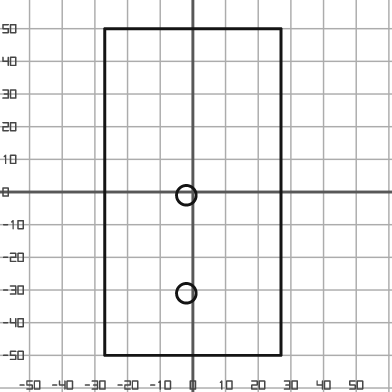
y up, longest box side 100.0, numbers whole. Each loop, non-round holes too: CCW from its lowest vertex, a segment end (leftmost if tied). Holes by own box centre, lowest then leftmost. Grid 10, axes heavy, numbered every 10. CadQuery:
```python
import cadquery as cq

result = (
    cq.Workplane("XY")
    .moveTo(-27.0, -50.0)
    .lineTo(27.0, -50.0)
    .lineTo(27.0, 50.0)
    .lineTo(-27.0, 50.0)
    .close()
    .moveTo(-2.0, -31.0)
    .circle(3.0)
    .moveTo(-2.0, -1.0)
    .circle(3.0)
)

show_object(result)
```